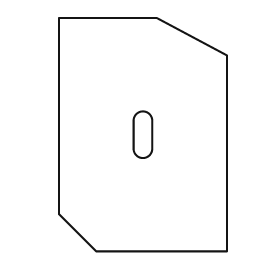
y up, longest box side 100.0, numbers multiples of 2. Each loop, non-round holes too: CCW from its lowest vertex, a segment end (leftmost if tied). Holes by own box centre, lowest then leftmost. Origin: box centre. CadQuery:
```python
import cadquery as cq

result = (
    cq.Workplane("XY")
    .moveTo(-20.0, -50.0)
    .lineTo(36.0, -50.0)
    .lineTo(36.0, 34.0)
    .lineTo(6.0, 50.0)
    .lineTo(-36.0, 50.0)
    .lineTo(-36.0, -34.0)
    .close()
    .moveTo(-4.0, -6.0)
    .threePointArc((0.0, -10.0), (4.0, -6.0))
    .lineTo(4.0, 6.0)
    .threePointArc((0.0, 10.0), (-4.0, 6.0))
    .close()
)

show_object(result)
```